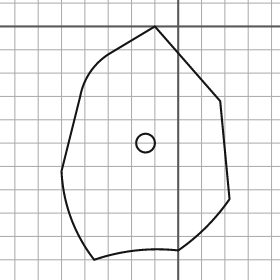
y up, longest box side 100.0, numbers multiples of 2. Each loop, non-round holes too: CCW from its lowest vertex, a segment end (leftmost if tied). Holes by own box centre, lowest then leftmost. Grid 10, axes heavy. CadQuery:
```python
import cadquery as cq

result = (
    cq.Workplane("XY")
    .moveTo(-36.0, -100.0)
    .threePointArc((-18.0, -96.0), (0.0, -96.0))
    .threePointArc((12.0, -86.0), (22.0, -74.0))
    .lineTo(18.0, -32.0)
    .lineTo(-10.0, 0.0)
    .lineTo(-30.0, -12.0)
    .threePointArc((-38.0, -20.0), (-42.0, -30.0))
    .lineTo(-50.0, -62.0)
    .threePointArc((-46.0, -82.0), (-36.0, -100.0))
    .close()
    .moveTo(-14.0, -50.0)
    .circle(4.0)
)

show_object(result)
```